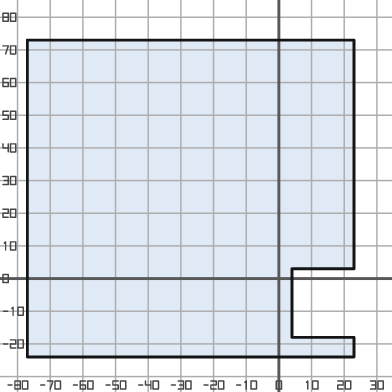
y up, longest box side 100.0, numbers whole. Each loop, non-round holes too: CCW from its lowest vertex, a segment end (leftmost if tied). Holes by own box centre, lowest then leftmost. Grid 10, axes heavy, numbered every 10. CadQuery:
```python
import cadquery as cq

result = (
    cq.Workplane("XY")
    .moveTo(-77.0, -24.0)
    .lineTo(23.0, -24.0)
    .lineTo(23.0, -18.0)
    .lineTo(4.0, -18.0)
    .lineTo(4.0, 3.0)
    .lineTo(23.0, 3.0)
    .lineTo(23.0, 73.0)
    .lineTo(-77.0, 73.0)
    .close()
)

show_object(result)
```